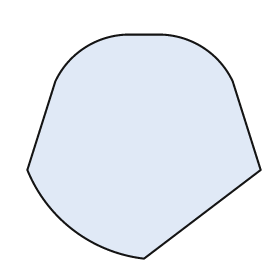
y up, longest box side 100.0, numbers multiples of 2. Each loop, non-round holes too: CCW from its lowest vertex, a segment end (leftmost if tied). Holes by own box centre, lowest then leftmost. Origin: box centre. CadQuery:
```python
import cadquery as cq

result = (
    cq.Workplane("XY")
    .moveTo(0.0, -48.0)
    .lineTo(50.0, -10.0)
    .lineTo(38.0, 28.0)
    .threePointArc((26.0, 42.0), (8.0, 48.0))
    .lineTo(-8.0, 48.0)
    .threePointArc((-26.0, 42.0), (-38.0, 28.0))
    .lineTo(-50.0, -10.0)
    .threePointArc((-30.0, -36.0), (0.0, -48.0))
    .close()
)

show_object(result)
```